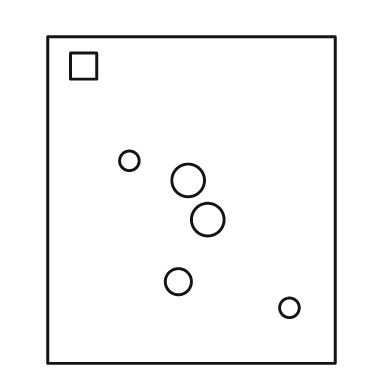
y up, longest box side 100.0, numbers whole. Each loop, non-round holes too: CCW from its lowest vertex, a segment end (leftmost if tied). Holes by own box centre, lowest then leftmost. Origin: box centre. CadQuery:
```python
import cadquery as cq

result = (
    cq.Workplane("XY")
    .moveTo(-44.0, -50.0)
    .lineTo(44.0, -50.0)
    .lineTo(44.0, 50.0)
    .lineTo(-44.0, 50.0)
    .close()
    .moveTo(30.0, -33.0)
    .circle(3.0)
    .moveTo(-4.0, -25.0)
    .circle(4.0)
    .moveTo(5.0, -6.0)
    .circle(5.0)
    .moveTo(-1.0, 6.0)
    .circle(5.0)
    .moveTo(-19.0, 12.0)
    .circle(3.0)
    .moveTo(-37.0, 37.0)
    .lineTo(-29.0, 37.0)
    .lineTo(-29.0, 45.0)
    .lineTo(-37.0, 45.0)
    .close()
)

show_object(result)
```